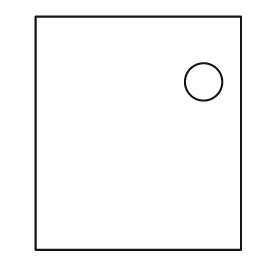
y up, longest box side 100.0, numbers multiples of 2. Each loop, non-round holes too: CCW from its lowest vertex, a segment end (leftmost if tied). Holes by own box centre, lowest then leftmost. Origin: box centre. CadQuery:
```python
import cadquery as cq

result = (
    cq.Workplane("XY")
    .moveTo(-44.0, -50.0)
    .lineTo(44.0, -50.0)
    .lineTo(44.0, 50.0)
    .lineTo(-44.0, 50.0)
    .close()
    .moveTo(28.0, 22.0)
    .circle(8.0)
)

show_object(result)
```